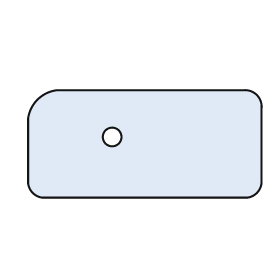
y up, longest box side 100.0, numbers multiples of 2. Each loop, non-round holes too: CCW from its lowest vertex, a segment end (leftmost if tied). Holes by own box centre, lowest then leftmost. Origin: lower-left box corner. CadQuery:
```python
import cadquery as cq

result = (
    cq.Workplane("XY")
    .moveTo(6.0, 0.0)
    .lineTo(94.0, 0.0)
    .threePointArc((98.0, 2.0), (100.0, 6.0))
    .lineTo(100.0, 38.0)
    .threePointArc((98.0, 44.0), (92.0, 46.0))
    .lineTo(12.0, 46.0)
    .threePointArc((4.0, 42.0), (0.0, 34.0))
    .lineTo(0.0, 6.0)
    .threePointArc((2.0, 2.0), (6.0, 0.0))
    .close()
    .moveTo(36.0, 26.0)
    .circle(4.0)
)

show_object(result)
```